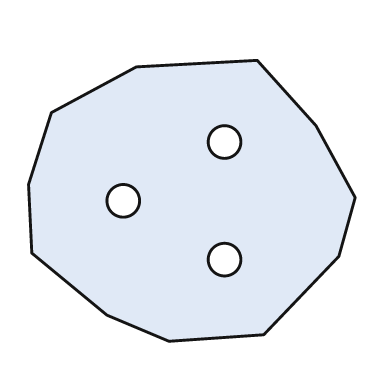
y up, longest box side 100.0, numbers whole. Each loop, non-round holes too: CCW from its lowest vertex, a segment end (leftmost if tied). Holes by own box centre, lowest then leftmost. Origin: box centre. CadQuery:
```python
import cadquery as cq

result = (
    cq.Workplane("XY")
    .moveTo(-7.0, -43.0)
    .lineTo(22.0, -41.0)
    .lineTo(45.0, -17.0)
    .lineTo(50.0, 1.0)
    .lineTo(38.0, 23.0)
    .lineTo(20.0, 43.0)
    .lineTo(-17.0, 41.0)
    .lineTo(-43.0, 27.0)
    .lineTo(-50.0, 5.0)
    .lineTo(-49.0, -16.0)
    .lineTo(-26.0, -35.0)
    .close()
    .moveTo(10.0, -18.0)
    .circle(5.0)
    .moveTo(-21.0, 0.0)
    .circle(5.0)
    .moveTo(10.0, 18.0)
    .circle(5.0)
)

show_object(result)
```